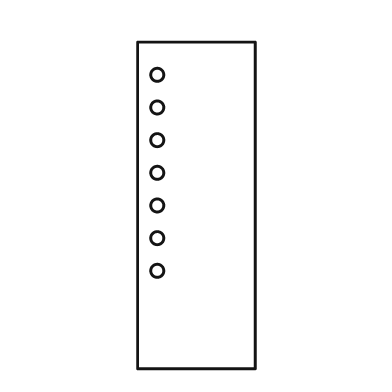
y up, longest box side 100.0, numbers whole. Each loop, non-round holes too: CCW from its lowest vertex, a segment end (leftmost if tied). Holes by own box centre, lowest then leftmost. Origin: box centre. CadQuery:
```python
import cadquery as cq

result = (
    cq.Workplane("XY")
    .moveTo(-18.0, -50.0)
    .lineTo(18.0, -50.0)
    .lineTo(18.0, 50.0)
    .lineTo(-18.0, 50.0)
    .close()
    .moveTo(-12.0, -20.0)
    .circle(2.0)
    .moveTo(-12.0, -10.0)
    .circle(2.0)
    .moveTo(-12.0, 0.0)
    .circle(2.0)
    .moveTo(-12.0, 10.0)
    .circle(2.0)
    .moveTo(-12.0, 20.0)
    .circle(2.0)
    .moveTo(-12.0, 30.0)
    .circle(2.0)
    .moveTo(-12.0, 40.0)
    .circle(2.0)
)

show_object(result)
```